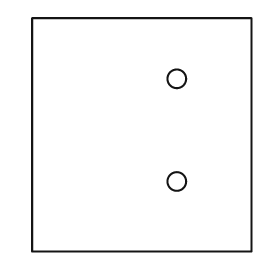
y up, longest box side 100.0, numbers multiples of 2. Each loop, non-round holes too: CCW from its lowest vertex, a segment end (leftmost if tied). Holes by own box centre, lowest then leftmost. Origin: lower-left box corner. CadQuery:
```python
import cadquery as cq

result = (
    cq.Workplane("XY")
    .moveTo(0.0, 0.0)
    .lineTo(94.0, 0.0)
    .lineTo(94.0, 100.0)
    .lineTo(0.0, 100.0)
    .close()
    .moveTo(62.0, 30.0)
    .circle(4.0)
    .moveTo(62.0, 74.0)
    .circle(4.0)
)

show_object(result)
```